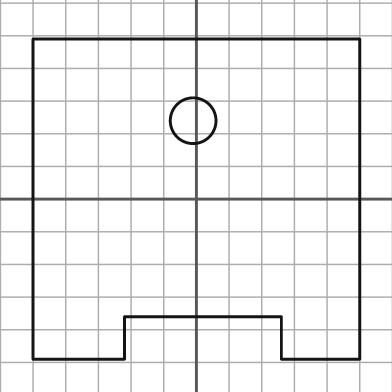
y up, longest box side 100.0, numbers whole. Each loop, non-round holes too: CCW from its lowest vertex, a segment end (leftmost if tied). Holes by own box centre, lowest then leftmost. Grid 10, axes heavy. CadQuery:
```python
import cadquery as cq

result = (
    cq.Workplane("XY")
    .moveTo(-50.0, -49.0)
    .lineTo(-22.0, -49.0)
    .lineTo(-22.0, -36.0)
    .lineTo(26.0, -36.0)
    .lineTo(26.0, -49.0)
    .lineTo(50.0, -49.0)
    .lineTo(50.0, 49.0)
    .lineTo(-50.0, 49.0)
    .close()
    .moveTo(-1.0, 24.0)
    .circle(7.0)
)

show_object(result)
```